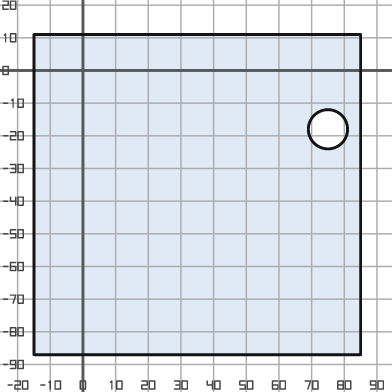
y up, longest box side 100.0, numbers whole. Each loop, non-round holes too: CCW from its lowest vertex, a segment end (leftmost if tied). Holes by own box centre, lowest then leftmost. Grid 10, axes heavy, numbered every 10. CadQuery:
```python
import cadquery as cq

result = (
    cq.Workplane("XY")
    .moveTo(-15.0, -87.0)
    .lineTo(85.0, -87.0)
    .lineTo(85.0, 11.0)
    .lineTo(-15.0, 11.0)
    .close()
    .moveTo(75.0, -18.0)
    .circle(6.0)
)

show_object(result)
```